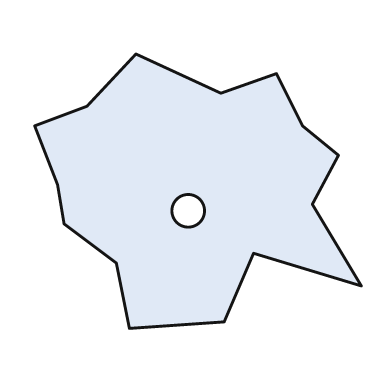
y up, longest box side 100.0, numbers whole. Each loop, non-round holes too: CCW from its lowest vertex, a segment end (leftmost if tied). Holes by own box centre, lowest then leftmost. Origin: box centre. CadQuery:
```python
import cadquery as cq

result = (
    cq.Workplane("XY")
    .moveTo(-21.0, -42.0)
    .lineTo(8.0, -40.0)
    .lineTo(17.0, -19.0)
    .lineTo(50.0, -29.0)
    .lineTo(35.0, -4.0)
    .lineTo(43.0, 11.0)
    .lineTo(32.0, 20.0)
    .lineTo(24.0, 36.0)
    .lineTo(7.0, 30.0)
    .lineTo(-19.0, 42.0)
    .lineTo(-34.0, 26.0)
    .lineTo(-50.0, 20.0)
    .lineTo(-43.0, 2.0)
    .lineTo(-41.0, -10.0)
    .lineTo(-25.0, -22.0)
    .close()
    .moveTo(-3.0, -6.0)
    .circle(5.0)
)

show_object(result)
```